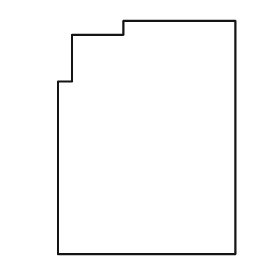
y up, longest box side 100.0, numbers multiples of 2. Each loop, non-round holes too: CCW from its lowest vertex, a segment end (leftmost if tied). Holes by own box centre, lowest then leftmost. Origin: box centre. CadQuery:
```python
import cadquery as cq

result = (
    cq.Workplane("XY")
    .moveTo(-38.0, -50.0)
    .lineTo(38.0, -50.0)
    .lineTo(38.0, 50.0)
    .lineTo(-10.0, 50.0)
    .lineTo(-10.0, 44.0)
    .lineTo(-32.0, 44.0)
    .lineTo(-32.0, 24.0)
    .lineTo(-38.0, 24.0)
    .close()
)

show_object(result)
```